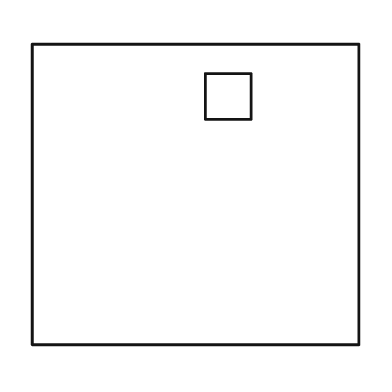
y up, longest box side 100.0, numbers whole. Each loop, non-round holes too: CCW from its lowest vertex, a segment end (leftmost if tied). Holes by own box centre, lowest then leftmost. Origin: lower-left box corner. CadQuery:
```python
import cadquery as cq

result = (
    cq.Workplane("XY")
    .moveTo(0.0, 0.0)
    .lineTo(100.0, 0.0)
    .lineTo(100.0, 92.0)
    .lineTo(0.0, 92.0)
    .close()
    .moveTo(53.0, 69.0)
    .lineTo(67.0, 69.0)
    .lineTo(67.0, 83.0)
    .lineTo(53.0, 83.0)
    .close()
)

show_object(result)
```